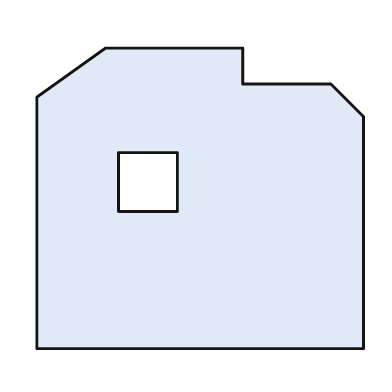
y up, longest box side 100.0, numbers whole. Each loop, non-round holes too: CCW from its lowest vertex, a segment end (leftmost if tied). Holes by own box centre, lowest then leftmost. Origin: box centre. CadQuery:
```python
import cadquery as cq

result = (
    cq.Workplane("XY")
    .moveTo(-50.0, -46.0)
    .lineTo(50.0, -46.0)
    .lineTo(50.0, 25.0)
    .lineTo(40.0, 35.0)
    .lineTo(13.0, 35.0)
    .lineTo(13.0, 46.0)
    .lineTo(-29.0, 46.0)
    .lineTo(-50.0, 31.0)
    .close()
    .moveTo(-25.0, -4.0)
    .lineTo(-7.0, -4.0)
    .lineTo(-7.0, 14.0)
    .lineTo(-25.0, 14.0)
    .close()
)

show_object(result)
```